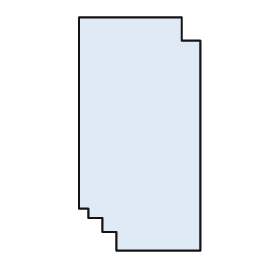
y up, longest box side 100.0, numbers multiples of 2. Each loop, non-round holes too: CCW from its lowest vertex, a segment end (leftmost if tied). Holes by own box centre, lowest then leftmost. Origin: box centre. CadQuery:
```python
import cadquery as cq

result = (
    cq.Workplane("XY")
    .moveTo(-10.0, -50.0)
    .lineTo(26.0, -50.0)
    .lineTo(26.0, 40.0)
    .lineTo(18.0, 40.0)
    .lineTo(18.0, 50.0)
    .lineTo(-26.0, 50.0)
    .lineTo(-26.0, -32.0)
    .lineTo(-22.0, -32.0)
    .lineTo(-22.0, -36.0)
    .lineTo(-16.0, -36.0)
    .lineTo(-16.0, -42.0)
    .lineTo(-10.0, -42.0)
    .close()
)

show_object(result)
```